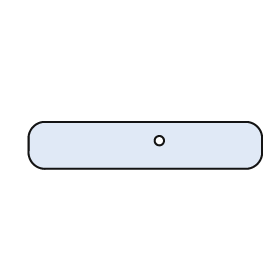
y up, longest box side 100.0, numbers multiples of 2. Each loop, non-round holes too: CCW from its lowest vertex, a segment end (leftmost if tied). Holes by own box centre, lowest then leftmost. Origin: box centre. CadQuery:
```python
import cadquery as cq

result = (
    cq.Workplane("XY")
    .moveTo(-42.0, -10.0)
    .lineTo(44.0, -10.0)
    .threePointArc((48.0, -8.0), (50.0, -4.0))
    .lineTo(50.0, 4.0)
    .threePointArc((48.0, 8.0), (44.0, 10.0))
    .lineTo(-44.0, 10.0)
    .threePointArc((-48.0, 8.0), (-50.0, 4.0))
    .lineTo(-50.0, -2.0)
    .threePointArc((-48.0, -8.0), (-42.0, -10.0))
    .close()
    .moveTo(6.0, 2.0)
    .circle(2.0)
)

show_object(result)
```